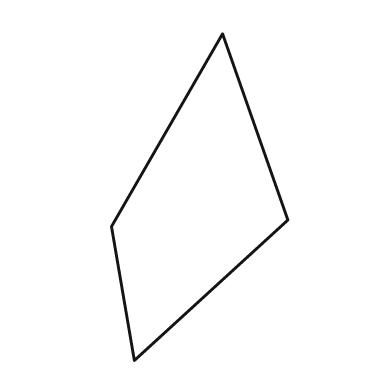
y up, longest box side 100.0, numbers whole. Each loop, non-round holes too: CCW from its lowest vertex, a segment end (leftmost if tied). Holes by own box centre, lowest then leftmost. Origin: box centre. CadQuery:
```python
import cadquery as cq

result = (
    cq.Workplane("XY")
    .moveTo(-20.0, -50.0)
    .lineTo(27.0, -7.0)
    .lineTo(7.0, 50.0)
    .lineTo(-27.0, -9.0)
    .close()
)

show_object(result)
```